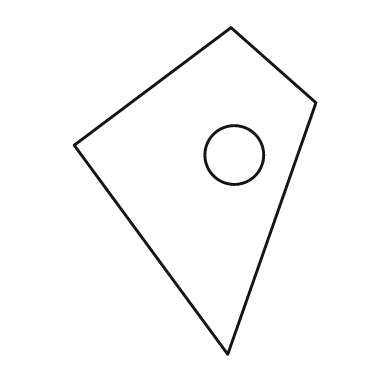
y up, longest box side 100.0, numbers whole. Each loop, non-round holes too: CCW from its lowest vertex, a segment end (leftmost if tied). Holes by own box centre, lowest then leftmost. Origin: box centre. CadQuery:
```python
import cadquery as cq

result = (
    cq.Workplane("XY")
    .moveTo(10.0, -50.0)
    .lineTo(37.0, 27.0)
    .lineTo(11.0, 50.0)
    .lineTo(-37.0, 14.0)
    .close()
    .moveTo(12.0, 11.0)
    .circle(9.0)
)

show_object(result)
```